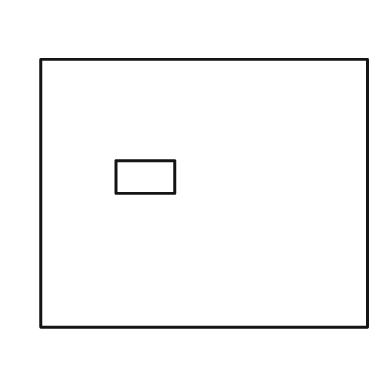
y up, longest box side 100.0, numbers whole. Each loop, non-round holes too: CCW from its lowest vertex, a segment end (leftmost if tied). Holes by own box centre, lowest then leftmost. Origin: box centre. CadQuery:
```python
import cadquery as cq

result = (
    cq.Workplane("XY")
    .moveTo(-50.0, -41.0)
    .lineTo(50.0, -41.0)
    .lineTo(50.0, 41.0)
    .lineTo(-50.0, 41.0)
    .close()
    .moveTo(-27.0, 0.0)
    .lineTo(-9.0, 0.0)
    .lineTo(-9.0, 10.0)
    .lineTo(-27.0, 10.0)
    .close()
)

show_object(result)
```